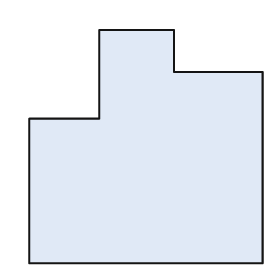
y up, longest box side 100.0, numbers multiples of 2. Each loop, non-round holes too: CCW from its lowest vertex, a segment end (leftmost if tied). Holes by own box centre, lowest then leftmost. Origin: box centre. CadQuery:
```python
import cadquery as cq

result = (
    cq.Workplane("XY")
    .moveTo(-50.0, -50.0)
    .lineTo(50.0, -50.0)
    .lineTo(50.0, 32.0)
    .lineTo(12.0, 32.0)
    .lineTo(12.0, 50.0)
    .lineTo(-20.0, 50.0)
    .lineTo(-20.0, 12.0)
    .lineTo(-50.0, 12.0)
    .close()
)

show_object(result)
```